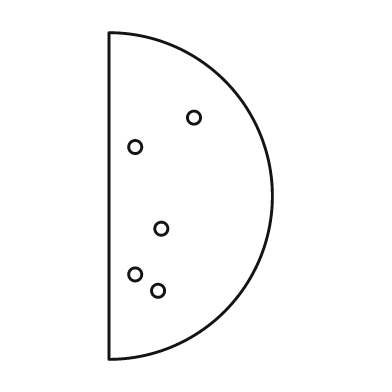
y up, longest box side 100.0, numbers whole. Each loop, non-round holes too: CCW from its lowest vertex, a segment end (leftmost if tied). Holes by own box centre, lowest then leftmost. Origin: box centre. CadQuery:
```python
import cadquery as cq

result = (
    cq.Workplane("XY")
    .moveTo(-25.0, -50.0)
    .threePointArc((25.0, 0.0), (-25.0, 50.0))
    .close()
    .moveTo(-10.0, -29.0)
    .circle(2.0)
    .moveTo(-17.0, -24.0)
    .circle(2.0)
    .moveTo(-9.0, -10.0)
    .circle(2.0)
    .moveTo(-17.0, 15.0)
    .circle(2.0)
    .moveTo(1.0, 24.0)
    .circle(2.0)
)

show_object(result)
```